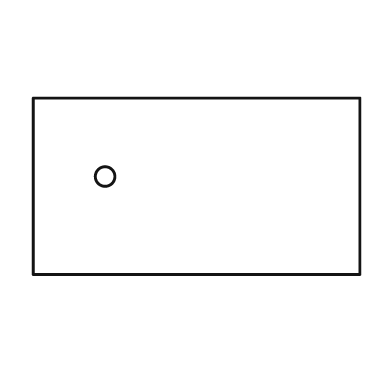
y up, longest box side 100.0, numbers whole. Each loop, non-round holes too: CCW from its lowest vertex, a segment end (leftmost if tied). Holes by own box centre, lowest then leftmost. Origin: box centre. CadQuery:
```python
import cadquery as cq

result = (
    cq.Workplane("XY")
    .moveTo(-50.0, -27.0)
    .lineTo(50.0, -27.0)
    .lineTo(50.0, 27.0)
    .lineTo(-50.0, 27.0)
    .close()
    .moveTo(-28.0, 3.0)
    .circle(3.0)
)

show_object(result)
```